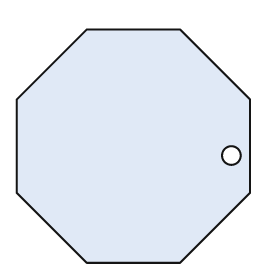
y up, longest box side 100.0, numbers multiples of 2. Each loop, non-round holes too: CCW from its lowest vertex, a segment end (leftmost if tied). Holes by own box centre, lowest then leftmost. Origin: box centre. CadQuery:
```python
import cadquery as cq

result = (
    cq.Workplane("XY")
    .moveTo(-20.0, -50.0)
    .lineTo(20.0, -50.0)
    .lineTo(50.0, -20.0)
    .lineTo(50.0, 20.0)
    .lineTo(20.0, 50.0)
    .lineTo(-20.0, 50.0)
    .lineTo(-50.0, 20.0)
    .lineTo(-50.0, -20.0)
    .close()
    .moveTo(42.0, -4.0)
    .circle(4.0)
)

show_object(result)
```